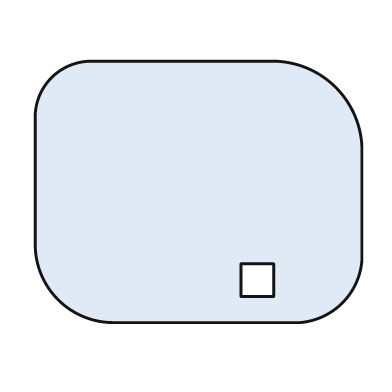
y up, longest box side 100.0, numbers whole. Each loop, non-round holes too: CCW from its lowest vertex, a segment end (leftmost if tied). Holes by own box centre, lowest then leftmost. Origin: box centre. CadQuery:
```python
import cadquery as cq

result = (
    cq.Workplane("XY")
    .moveTo(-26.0, -40.0)
    .lineTo(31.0, -40.0)
    .threePointArc((44.0, -34.0), (50.0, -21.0))
    .lineTo(50.0, 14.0)
    .threePointArc((42.0, 32.0), (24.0, 40.0))
    .lineTo(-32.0, 40.0)
    .threePointArc((-45.0, 35.0), (-50.0, 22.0))
    .lineTo(-50.0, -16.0)
    .threePointArc((-43.0, -33.0), (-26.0, -40.0))
    .close()
    .moveTo(13.0, -32.0)
    .lineTo(23.0, -32.0)
    .lineTo(23.0, -22.0)
    .lineTo(13.0, -22.0)
    .close()
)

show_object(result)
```